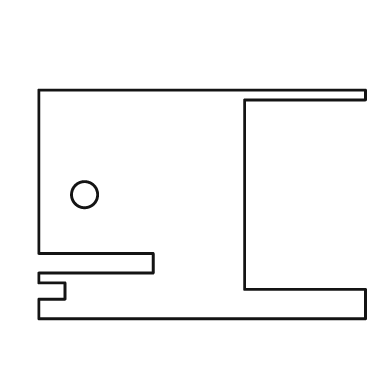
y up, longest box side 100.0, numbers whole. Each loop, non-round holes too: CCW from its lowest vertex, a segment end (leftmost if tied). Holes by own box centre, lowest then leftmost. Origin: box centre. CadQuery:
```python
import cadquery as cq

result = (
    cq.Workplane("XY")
    .moveTo(-50.0, -35.0)
    .lineTo(50.0, -35.0)
    .lineTo(50.0, -26.0)
    .lineTo(13.0, -26.0)
    .lineTo(13.0, 32.0)
    .lineTo(50.0, 32.0)
    .lineTo(50.0, 35.0)
    .lineTo(-50.0, 35.0)
    .lineTo(-50.0, -15.0)
    .lineTo(-15.0, -15.0)
    .lineTo(-15.0, -21.0)
    .lineTo(-50.0, -21.0)
    .lineTo(-50.0, -24.0)
    .lineTo(-42.0, -24.0)
    .lineTo(-42.0, -29.0)
    .lineTo(-50.0, -29.0)
    .close()
    .moveTo(-36.0, 3.0)
    .circle(4.0)
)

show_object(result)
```